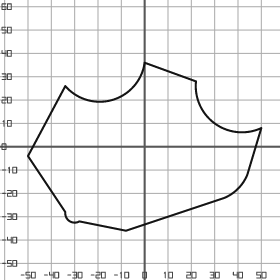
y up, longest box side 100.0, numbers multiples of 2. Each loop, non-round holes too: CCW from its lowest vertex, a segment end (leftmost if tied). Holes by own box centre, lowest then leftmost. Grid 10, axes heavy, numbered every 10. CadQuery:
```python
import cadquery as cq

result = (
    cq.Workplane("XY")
    .moveTo(-8.0, -36.0)
    .lineTo(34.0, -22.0)
    .threePointArc((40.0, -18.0), (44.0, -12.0))
    .lineTo(50.0, 8.0)
    .threePointArc((30.0, 10.0), (22.0, 28.0))
    .lineTo(0.0, 36.0)
    .threePointArc((-14.0, 20.0), (-34.0, 26.0))
    .lineTo(-50.0, -4.0)
    .lineTo(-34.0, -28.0)
    .threePointArc((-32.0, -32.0), (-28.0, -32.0))
    .close()
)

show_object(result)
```